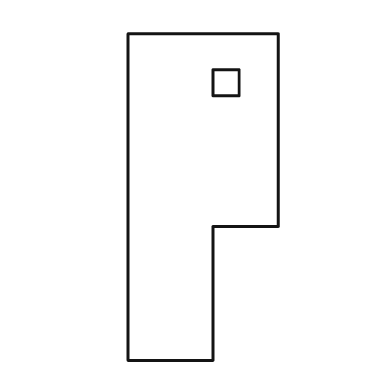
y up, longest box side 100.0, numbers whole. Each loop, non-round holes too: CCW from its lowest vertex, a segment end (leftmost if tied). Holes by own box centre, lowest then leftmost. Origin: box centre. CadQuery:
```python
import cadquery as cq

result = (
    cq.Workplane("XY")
    .moveTo(-23.0, -50.0)
    .lineTo(3.0, -50.0)
    .lineTo(3.0, -9.0)
    .lineTo(23.0, -9.0)
    .lineTo(23.0, 50.0)
    .lineTo(-23.0, 50.0)
    .close()
    .moveTo(3.0, 31.0)
    .lineTo(11.0, 31.0)
    .lineTo(11.0, 39.0)
    .lineTo(3.0, 39.0)
    .close()
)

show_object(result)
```